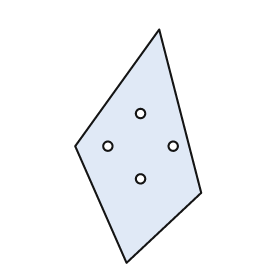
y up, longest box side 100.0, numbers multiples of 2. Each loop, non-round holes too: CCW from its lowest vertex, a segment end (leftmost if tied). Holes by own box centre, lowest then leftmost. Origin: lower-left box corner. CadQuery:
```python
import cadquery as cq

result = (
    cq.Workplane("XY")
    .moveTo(22.0, 0.0)
    .lineTo(54.0, 30.0)
    .lineTo(36.0, 100.0)
    .lineTo(0.0, 50.0)
    .close()
    .moveTo(28.0, 36.0)
    .circle(2.0)
    .moveTo(14.0, 50.0)
    .circle(2.0)
    .moveTo(42.0, 50.0)
    .circle(2.0)
    .moveTo(28.0, 64.0)
    .circle(2.0)
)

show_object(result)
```